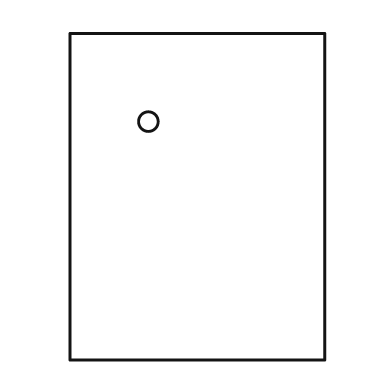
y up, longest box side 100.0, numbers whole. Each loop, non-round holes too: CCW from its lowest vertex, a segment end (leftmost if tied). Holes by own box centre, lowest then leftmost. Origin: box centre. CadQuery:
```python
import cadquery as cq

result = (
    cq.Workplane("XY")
    .moveTo(-39.0, -50.0)
    .lineTo(39.0, -50.0)
    .lineTo(39.0, 50.0)
    .lineTo(-39.0, 50.0)
    .close()
    .moveTo(-15.0, 23.0)
    .circle(3.0)
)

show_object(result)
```